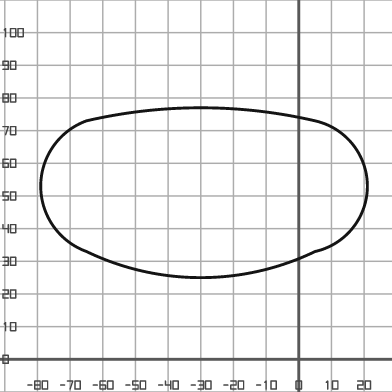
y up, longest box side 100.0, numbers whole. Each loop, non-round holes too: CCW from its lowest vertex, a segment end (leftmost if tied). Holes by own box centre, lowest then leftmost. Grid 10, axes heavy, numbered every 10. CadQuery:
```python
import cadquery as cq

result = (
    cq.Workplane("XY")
    .moveTo(-65.0, 33.0)
    .threePointArc((-30.0, 25.0), (5.0, 33.0))
    .threePointArc((21.0, 53.0), (5.0, 73.0))
    .threePointArc((-30.0, 77.0), (-65.0, 73.0))
    .threePointArc((-79.0, 53.0), (-65.0, 33.0))
    .close()
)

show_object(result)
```